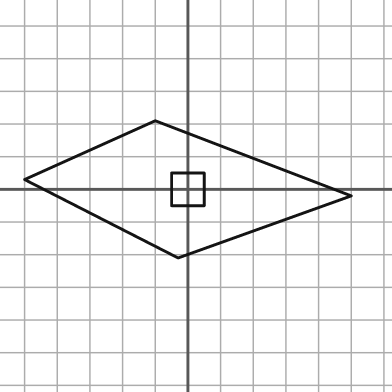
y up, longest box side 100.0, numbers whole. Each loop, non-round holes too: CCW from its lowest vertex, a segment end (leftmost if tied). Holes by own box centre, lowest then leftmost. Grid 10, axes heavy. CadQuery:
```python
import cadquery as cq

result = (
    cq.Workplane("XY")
    .moveTo(-3.0, -21.0)
    .lineTo(50.0, -2.0)
    .lineTo(-10.0, 21.0)
    .lineTo(-50.0, 3.0)
    .close()
    .moveTo(-5.0, -5.0)
    .lineTo(5.0, -5.0)
    .lineTo(5.0, 5.0)
    .lineTo(-5.0, 5.0)
    .close()
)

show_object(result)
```